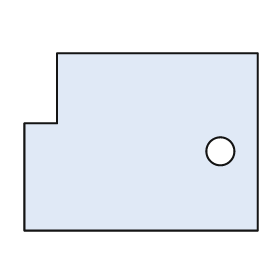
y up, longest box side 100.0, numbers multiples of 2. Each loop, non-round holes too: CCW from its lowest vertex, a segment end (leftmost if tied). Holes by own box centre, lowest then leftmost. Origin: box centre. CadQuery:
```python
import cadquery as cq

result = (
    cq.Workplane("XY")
    .moveTo(-50.0, -38.0)
    .lineTo(50.0, -38.0)
    .lineTo(50.0, 38.0)
    .lineTo(-36.0, 38.0)
    .lineTo(-36.0, 8.0)
    .lineTo(-50.0, 8.0)
    .close()
    .moveTo(34.0, -4.0)
    .circle(6.0)
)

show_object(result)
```